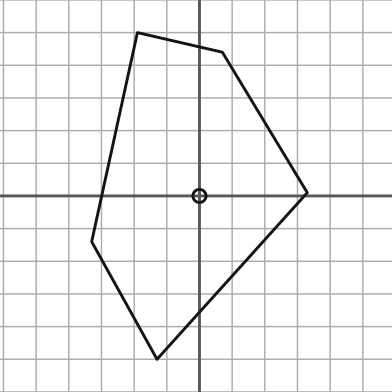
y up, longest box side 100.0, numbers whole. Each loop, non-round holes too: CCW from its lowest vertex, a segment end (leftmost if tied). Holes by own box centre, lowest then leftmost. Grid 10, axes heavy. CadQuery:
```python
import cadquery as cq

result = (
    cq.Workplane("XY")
    .moveTo(-13.0, -50.0)
    .lineTo(33.0, 1.0)
    .lineTo(7.0, 44.0)
    .lineTo(-19.0, 50.0)
    .lineTo(-33.0, -14.0)
    .close()
    .moveTo(0.0, 0.0)
    .circle(2.0)
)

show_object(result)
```